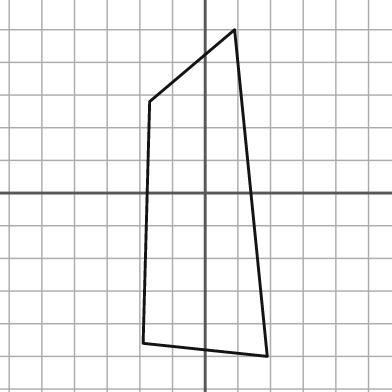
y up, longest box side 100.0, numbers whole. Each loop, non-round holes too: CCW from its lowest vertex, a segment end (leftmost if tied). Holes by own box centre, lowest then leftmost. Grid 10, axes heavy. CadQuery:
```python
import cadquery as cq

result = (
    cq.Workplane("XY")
    .moveTo(19.0, -50.0)
    .lineTo(9.0, 50.0)
    .lineTo(-17.0, 28.0)
    .lineTo(-19.0, -46.0)
    .close()
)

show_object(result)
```